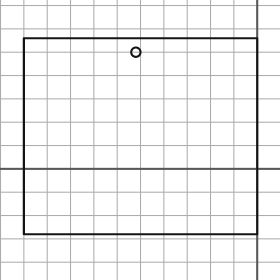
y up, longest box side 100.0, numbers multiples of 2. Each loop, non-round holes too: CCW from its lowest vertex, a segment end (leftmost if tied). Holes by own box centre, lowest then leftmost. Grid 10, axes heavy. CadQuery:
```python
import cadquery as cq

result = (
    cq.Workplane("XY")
    .moveTo(-100.0, -28.0)
    .lineTo(0.0, -28.0)
    .lineTo(0.0, 56.0)
    .lineTo(-100.0, 56.0)
    .close()
    .moveTo(-52.0, 50.0)
    .circle(2.0)
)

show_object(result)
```